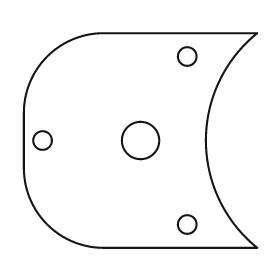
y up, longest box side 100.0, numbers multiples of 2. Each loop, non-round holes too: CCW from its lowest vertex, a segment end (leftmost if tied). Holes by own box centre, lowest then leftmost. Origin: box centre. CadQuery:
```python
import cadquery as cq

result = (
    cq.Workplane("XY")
    .moveTo(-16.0, -46.0)
    .lineTo(50.0, -46.0)
    .threePointArc((28.0, 0.0), (50.0, 46.0))
    .lineTo(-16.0, 46.0)
    .threePointArc((-40.0, 36.0), (-50.0, 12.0))
    .lineTo(-50.0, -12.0)
    .threePointArc((-40.0, -36.0), (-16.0, -46.0))
    .close()
    .moveTo(20.0, -36.0)
    .circle(4.0)
    .moveTo(-42.0, 0.0)
    .circle(4.0)
    .moveTo(0.0, 0.0)
    .circle(8.0)
    .moveTo(20.0, 36.0)
    .circle(4.0)
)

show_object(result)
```